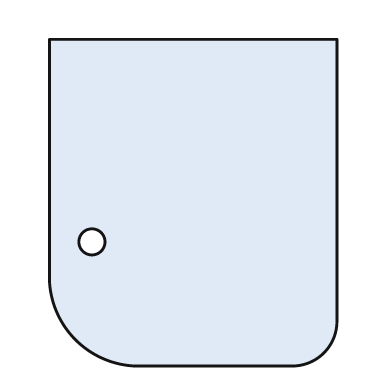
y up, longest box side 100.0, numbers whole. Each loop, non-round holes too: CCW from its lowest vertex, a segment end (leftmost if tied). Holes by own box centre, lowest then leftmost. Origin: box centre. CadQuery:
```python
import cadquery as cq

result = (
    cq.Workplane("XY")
    .moveTo(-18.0, -50.0)
    .lineTo(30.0, -50.0)
    .threePointArc((40.0, -46.0), (44.0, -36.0))
    .lineTo(44.0, 50.0)
    .lineTo(-44.0, 50.0)
    .lineTo(-44.0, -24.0)
    .threePointArc((-36.0, -42.0), (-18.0, -50.0))
    .close()
    .moveTo(-31.0, -12.0)
    .circle(4.0)
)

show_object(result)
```